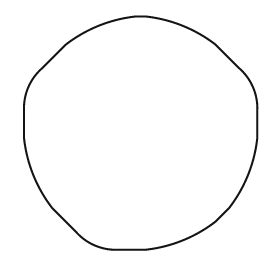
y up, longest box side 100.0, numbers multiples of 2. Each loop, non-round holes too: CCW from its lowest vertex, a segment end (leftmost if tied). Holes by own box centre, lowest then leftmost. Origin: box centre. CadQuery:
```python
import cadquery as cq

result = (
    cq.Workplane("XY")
    .moveTo(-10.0, -50.0)
    .lineTo(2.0, -50.0)
    .threePointArc((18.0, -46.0), (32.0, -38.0))
    .lineTo(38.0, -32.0)
    .threePointArc((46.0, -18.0), (50.0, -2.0))
    .lineTo(50.0, 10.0)
    .threePointArc((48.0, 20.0), (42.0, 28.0))
    .lineTo(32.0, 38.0)
    .threePointArc((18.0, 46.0), (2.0, 50.0))
    .lineTo(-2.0, 50.0)
    .threePointArc((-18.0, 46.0), (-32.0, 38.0))
    .lineTo(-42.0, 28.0)
    .threePointArc((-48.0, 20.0), (-50.0, 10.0))
    .lineTo(-50.0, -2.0)
    .threePointArc((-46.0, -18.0), (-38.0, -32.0))
    .lineTo(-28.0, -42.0)
    .threePointArc((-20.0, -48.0), (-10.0, -50.0))
    .close()
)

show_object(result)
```